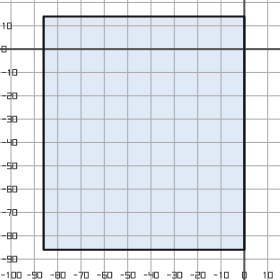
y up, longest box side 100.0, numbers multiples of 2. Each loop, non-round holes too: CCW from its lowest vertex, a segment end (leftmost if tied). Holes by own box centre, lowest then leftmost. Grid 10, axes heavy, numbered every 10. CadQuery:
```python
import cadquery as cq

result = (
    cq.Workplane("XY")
    .moveTo(-86.0, -86.0)
    .lineTo(0.0, -86.0)
    .lineTo(0.0, 14.0)
    .lineTo(-86.0, 14.0)
    .close()
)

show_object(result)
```